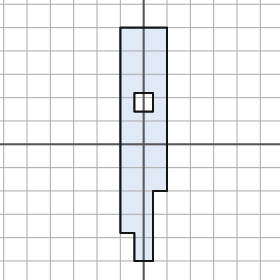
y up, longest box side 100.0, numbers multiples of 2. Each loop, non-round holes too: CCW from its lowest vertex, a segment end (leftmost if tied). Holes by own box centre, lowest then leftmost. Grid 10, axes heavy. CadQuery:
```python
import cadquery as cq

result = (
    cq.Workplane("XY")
    .moveTo(-4.0, -50.0)
    .lineTo(4.0, -50.0)
    .lineTo(4.0, -20.0)
    .lineTo(10.0, -20.0)
    .lineTo(10.0, 50.0)
    .lineTo(-10.0, 50.0)
    .lineTo(-10.0, -38.0)
    .lineTo(-4.0, -38.0)
    .close()
    .moveTo(-4.0, 14.0)
    .lineTo(4.0, 14.0)
    .lineTo(4.0, 22.0)
    .lineTo(-4.0, 22.0)
    .close()
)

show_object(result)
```